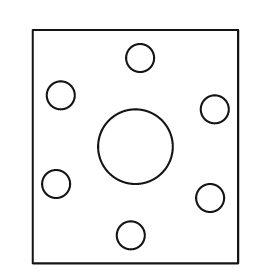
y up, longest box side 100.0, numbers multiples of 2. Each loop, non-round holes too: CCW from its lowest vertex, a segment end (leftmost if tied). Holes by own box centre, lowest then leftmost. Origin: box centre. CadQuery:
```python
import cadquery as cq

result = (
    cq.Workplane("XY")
    .moveTo(-44.0, -50.0)
    .lineTo(44.0, -50.0)
    .lineTo(44.0, 50.0)
    .lineTo(-44.0, 50.0)
    .close()
    .moveTo(-2.0, -38.0)
    .circle(6.0)
    .moveTo(32.0, -22.0)
    .circle(6.0)
    .moveTo(-34.0, -16.0)
    .circle(6.0)
    .moveTo(0.0, 0.0)
    .circle(16.0)
    .moveTo(34.0, 16.0)
    .circle(6.0)
    .moveTo(-32.0, 22.0)
    .circle(6.0)
    .moveTo(2.0, 38.0)
    .circle(6.0)
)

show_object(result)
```